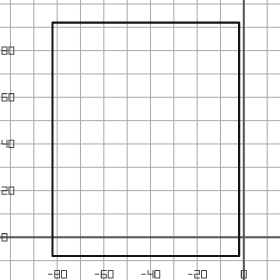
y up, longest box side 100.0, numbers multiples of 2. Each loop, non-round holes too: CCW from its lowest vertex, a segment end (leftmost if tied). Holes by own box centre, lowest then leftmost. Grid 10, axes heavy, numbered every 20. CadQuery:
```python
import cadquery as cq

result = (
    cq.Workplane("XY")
    .moveTo(-82.0, -8.0)
    .lineTo(-2.0, -8.0)
    .lineTo(-2.0, 92.0)
    .lineTo(-82.0, 92.0)
    .close()
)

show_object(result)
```